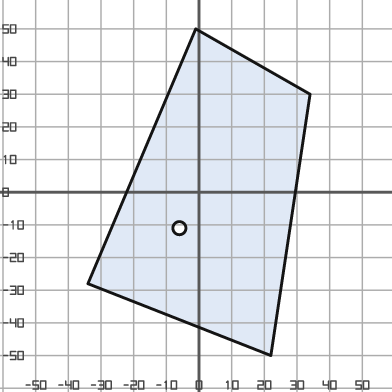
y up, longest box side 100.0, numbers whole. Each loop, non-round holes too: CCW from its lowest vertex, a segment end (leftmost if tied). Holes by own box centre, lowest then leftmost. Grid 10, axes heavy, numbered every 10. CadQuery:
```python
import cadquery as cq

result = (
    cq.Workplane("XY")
    .moveTo(22.0, -50.0)
    .lineTo(34.0, 30.0)
    .lineTo(-1.0, 50.0)
    .lineTo(-34.0, -28.0)
    .close()
    .moveTo(-6.0, -11.0)
    .circle(2.0)
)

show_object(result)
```